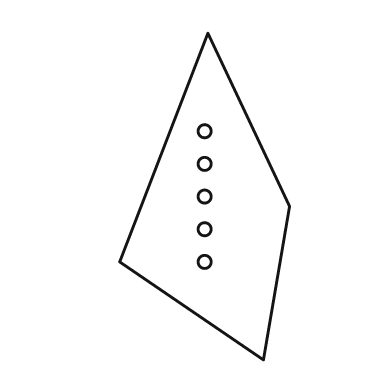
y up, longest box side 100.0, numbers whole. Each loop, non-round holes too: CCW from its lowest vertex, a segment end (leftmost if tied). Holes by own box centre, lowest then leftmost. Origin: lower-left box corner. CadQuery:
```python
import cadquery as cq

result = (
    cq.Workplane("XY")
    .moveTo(44.0, 0.0)
    .lineTo(52.0, 47.0)
    .lineTo(27.0, 100.0)
    .lineTo(0.0, 30.0)
    .close()
    .moveTo(26.0, 30.0)
    .circle(2.0)
    .moveTo(26.0, 40.0)
    .circle(2.0)
    .moveTo(26.0, 50.0)
    .circle(2.0)
    .moveTo(26.0, 60.0)
    .circle(2.0)
    .moveTo(26.0, 70.0)
    .circle(2.0)
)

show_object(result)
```